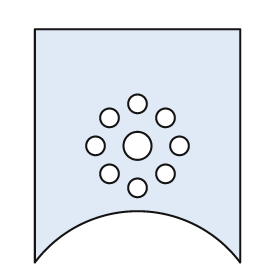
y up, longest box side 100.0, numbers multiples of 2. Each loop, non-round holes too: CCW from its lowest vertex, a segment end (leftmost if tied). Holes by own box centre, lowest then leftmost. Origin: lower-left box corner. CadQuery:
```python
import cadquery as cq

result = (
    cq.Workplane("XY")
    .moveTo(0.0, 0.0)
    .threePointArc((44.0, 22.0), (88.0, 0.0))
    .lineTo(88.0, 100.0)
    .lineTo(0.0, 100.0)
    .close()
    .moveTo(44.0, 32.0)
    .circle(4.0)
    .moveTo(32.0, 38.0)
    .circle(4.0)
    .moveTo(56.0, 38.0)
    .circle(4.0)
    .moveTo(26.0, 50.0)
    .circle(4.0)
    .moveTo(44.0, 50.0)
    .circle(6.0)
    .moveTo(62.0, 50.0)
    .circle(4.0)
    .moveTo(32.0, 62.0)
    .circle(4.0)
    .moveTo(56.0, 62.0)
    .circle(4.0)
    .moveTo(44.0, 68.0)
    .circle(4.0)
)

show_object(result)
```